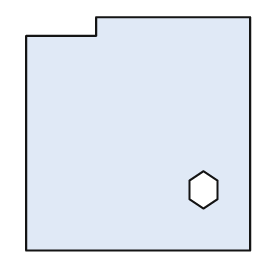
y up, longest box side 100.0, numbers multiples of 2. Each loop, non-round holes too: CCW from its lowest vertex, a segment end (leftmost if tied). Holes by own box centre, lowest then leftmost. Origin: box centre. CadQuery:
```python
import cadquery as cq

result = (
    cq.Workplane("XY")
    .moveTo(-48.0, -50.0)
    .lineTo(48.0, -50.0)
    .lineTo(48.0, 50.0)
    .lineTo(-18.0, 50.0)
    .lineTo(-18.0, 42.0)
    .lineTo(-48.0, 42.0)
    .close()
    .moveTo(28.0, -32.0)
    .lineTo(34.0, -28.0)
    .lineTo(34.0, -20.0)
    .lineTo(28.0, -16.0)
    .lineTo(22.0, -20.0)
    .lineTo(22.0, -28.0)
    .close()
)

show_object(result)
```